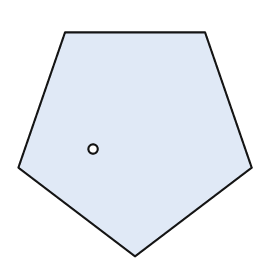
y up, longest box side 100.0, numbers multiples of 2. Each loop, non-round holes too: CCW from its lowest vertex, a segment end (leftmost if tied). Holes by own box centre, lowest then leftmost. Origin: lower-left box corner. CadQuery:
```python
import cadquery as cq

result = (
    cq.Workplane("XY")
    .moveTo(50.0, 0.0)
    .lineTo(100.0, 38.0)
    .lineTo(80.0, 96.0)
    .lineTo(20.0, 96.0)
    .lineTo(0.0, 38.0)
    .close()
    .moveTo(32.0, 46.0)
    .circle(2.0)
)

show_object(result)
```